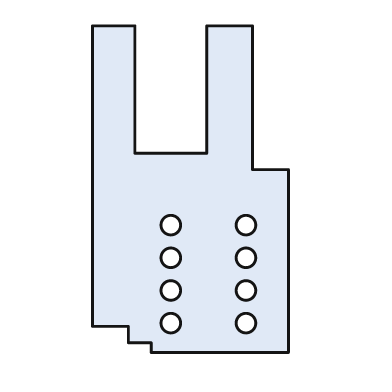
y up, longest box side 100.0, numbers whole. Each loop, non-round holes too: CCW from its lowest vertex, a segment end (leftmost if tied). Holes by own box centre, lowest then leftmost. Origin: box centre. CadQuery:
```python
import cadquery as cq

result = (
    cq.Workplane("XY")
    .moveTo(-12.0, -50.0)
    .lineTo(30.0, -50.0)
    .lineTo(30.0, 6.0)
    .lineTo(19.0, 6.0)
    .lineTo(19.0, 50.0)
    .lineTo(5.0, 50.0)
    .lineTo(5.0, 11.0)
    .lineTo(-17.0, 11.0)
    .lineTo(-17.0, 50.0)
    .lineTo(-30.0, 50.0)
    .lineTo(-30.0, -42.0)
    .lineTo(-19.0, -42.0)
    .lineTo(-19.0, -47.0)
    .lineTo(-12.0, -47.0)
    .close()
    .moveTo(-6.0, -41.0)
    .circle(3.0)
    .moveTo(17.0, -41.0)
    .circle(3.0)
    .moveTo(-6.0, -31.0)
    .circle(3.0)
    .moveTo(17.0, -31.0)
    .circle(3.0)
    .moveTo(-6.0, -21.0)
    .circle(3.0)
    .moveTo(17.0, -21.0)
    .circle(3.0)
    .moveTo(-6.0, -11.0)
    .circle(3.0)
    .moveTo(17.0, -11.0)
    .circle(3.0)
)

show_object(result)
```